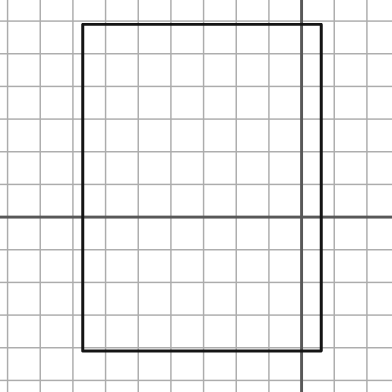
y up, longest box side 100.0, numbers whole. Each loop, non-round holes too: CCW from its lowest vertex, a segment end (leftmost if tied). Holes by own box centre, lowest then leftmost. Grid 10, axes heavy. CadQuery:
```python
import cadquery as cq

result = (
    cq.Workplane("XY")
    .moveTo(-67.0, -41.0)
    .lineTo(6.0, -41.0)
    .lineTo(6.0, 59.0)
    .lineTo(-67.0, 59.0)
    .close()
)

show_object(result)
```